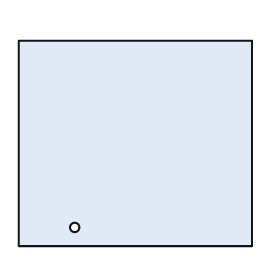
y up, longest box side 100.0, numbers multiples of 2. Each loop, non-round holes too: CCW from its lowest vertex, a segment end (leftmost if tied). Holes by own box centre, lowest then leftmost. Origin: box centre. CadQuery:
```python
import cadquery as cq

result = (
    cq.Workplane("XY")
    .moveTo(-50.0, -44.0)
    .lineTo(50.0, -44.0)
    .lineTo(50.0, 44.0)
    .lineTo(-50.0, 44.0)
    .close()
    .moveTo(-26.0, -36.0)
    .circle(2.0)
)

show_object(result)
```